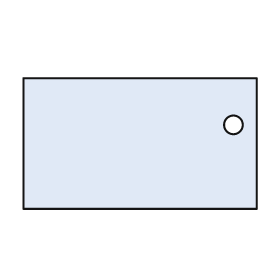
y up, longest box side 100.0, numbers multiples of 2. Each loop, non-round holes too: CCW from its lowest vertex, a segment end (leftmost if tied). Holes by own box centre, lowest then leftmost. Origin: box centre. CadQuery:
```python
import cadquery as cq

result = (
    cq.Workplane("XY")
    .moveTo(-50.0, -28.0)
    .lineTo(50.0, -28.0)
    .lineTo(50.0, 28.0)
    .lineTo(-50.0, 28.0)
    .close()
    .moveTo(40.0, 8.0)
    .circle(4.0)
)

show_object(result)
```